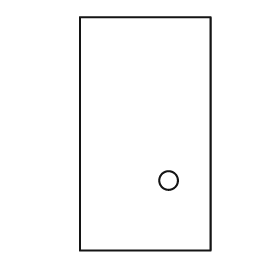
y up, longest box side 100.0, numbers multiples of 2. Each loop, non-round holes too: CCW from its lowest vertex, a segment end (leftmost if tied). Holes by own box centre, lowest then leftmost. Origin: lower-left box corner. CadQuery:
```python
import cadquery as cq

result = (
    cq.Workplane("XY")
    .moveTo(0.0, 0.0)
    .lineTo(56.0, 0.0)
    .lineTo(56.0, 100.0)
    .lineTo(0.0, 100.0)
    .close()
    .moveTo(38.0, 30.0)
    .circle(4.0)
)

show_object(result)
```